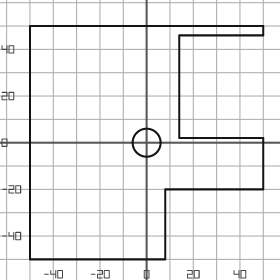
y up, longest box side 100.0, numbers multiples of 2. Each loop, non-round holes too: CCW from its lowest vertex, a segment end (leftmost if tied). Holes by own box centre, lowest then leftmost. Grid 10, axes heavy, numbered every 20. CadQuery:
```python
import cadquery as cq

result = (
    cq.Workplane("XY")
    .moveTo(-50.0, -50.0)
    .lineTo(8.0, -50.0)
    .lineTo(8.0, -20.0)
    .lineTo(50.0, -20.0)
    .lineTo(50.0, 2.0)
    .lineTo(14.0, 2.0)
    .lineTo(14.0, 46.0)
    .lineTo(50.0, 46.0)
    .lineTo(50.0, 50.0)
    .lineTo(-50.0, 50.0)
    .close()
    .moveTo(0.0, 0.0)
    .circle(6.0)
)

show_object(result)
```